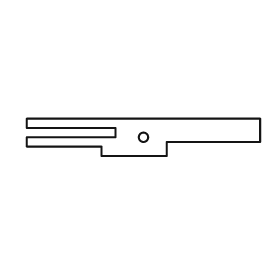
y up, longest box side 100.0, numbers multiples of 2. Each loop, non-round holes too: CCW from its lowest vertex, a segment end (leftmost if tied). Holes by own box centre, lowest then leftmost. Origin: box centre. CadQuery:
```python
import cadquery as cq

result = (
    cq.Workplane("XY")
    .moveTo(-18.0, -8.0)
    .lineTo(10.0, -8.0)
    .lineTo(10.0, -2.0)
    .lineTo(50.0, -2.0)
    .lineTo(50.0, 8.0)
    .lineTo(-50.0, 8.0)
    .lineTo(-50.0, 4.0)
    .lineTo(-12.0, 4.0)
    .lineTo(-12.0, 0.0)
    .lineTo(-50.0, 0.0)
    .lineTo(-50.0, -4.0)
    .lineTo(-18.0, -4.0)
    .close()
    .moveTo(0.0, 0.0)
    .circle(2.0)
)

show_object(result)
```